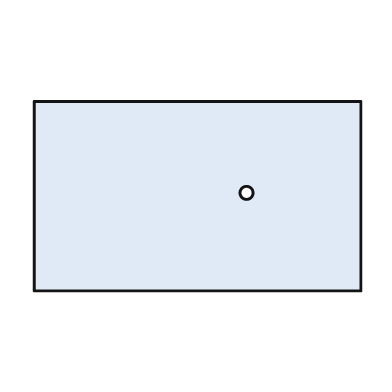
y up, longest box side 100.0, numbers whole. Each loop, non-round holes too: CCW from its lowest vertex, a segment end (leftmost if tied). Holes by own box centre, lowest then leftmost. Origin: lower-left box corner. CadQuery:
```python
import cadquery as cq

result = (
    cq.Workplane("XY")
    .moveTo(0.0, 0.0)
    .lineTo(100.0, 0.0)
    .lineTo(100.0, 58.0)
    .lineTo(0.0, 58.0)
    .close()
    .moveTo(65.0, 30.0)
    .circle(2.0)
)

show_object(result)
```